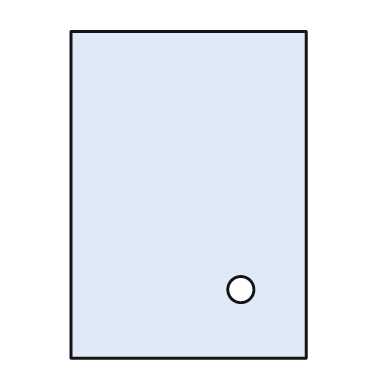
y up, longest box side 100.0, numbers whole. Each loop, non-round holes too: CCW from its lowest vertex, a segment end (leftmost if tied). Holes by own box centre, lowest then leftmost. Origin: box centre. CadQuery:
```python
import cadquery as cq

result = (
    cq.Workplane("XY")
    .moveTo(-36.0, -50.0)
    .lineTo(36.0, -50.0)
    .lineTo(36.0, 50.0)
    .lineTo(-36.0, 50.0)
    .close()
    .moveTo(16.0, -29.0)
    .circle(4.0)
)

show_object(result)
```